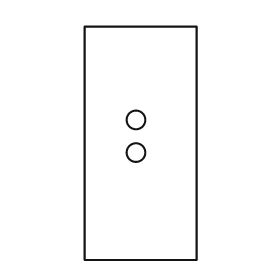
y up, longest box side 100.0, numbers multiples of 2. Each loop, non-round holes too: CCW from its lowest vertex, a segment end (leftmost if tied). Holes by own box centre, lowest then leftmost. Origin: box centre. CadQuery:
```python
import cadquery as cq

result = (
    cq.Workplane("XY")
    .moveTo(-24.0, -50.0)
    .lineTo(24.0, -50.0)
    .lineTo(24.0, 50.0)
    .lineTo(-24.0, 50.0)
    .close()
    .moveTo(-2.0, -4.0)
    .circle(4.0)
    .moveTo(-2.0, 10.0)
    .circle(4.0)
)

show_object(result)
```